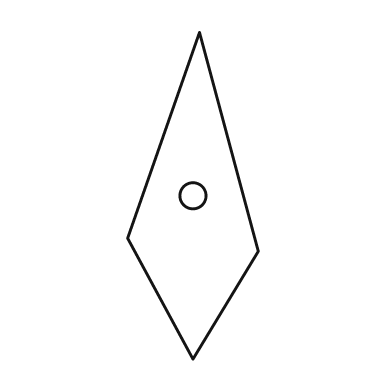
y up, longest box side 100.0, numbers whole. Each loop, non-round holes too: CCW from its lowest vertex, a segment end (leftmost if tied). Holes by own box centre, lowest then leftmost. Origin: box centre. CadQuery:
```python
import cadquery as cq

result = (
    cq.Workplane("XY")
    .moveTo(0.0, -50.0)
    .lineTo(20.0, -17.0)
    .lineTo(2.0, 50.0)
    .lineTo(-20.0, -13.0)
    .close()
    .moveTo(0.0, 0.0)
    .circle(4.0)
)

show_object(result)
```